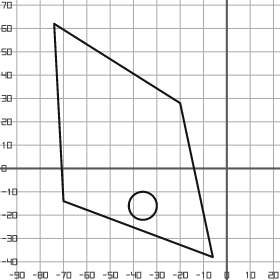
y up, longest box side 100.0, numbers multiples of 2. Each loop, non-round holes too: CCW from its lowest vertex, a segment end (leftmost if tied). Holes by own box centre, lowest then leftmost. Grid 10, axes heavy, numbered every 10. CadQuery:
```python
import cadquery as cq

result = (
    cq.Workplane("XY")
    .moveTo(-6.0, -38.0)
    .lineTo(-20.0, 28.0)
    .lineTo(-74.0, 62.0)
    .lineTo(-70.0, -14.0)
    .close()
    .moveTo(-36.0, -16.0)
    .circle(6.0)
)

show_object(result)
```